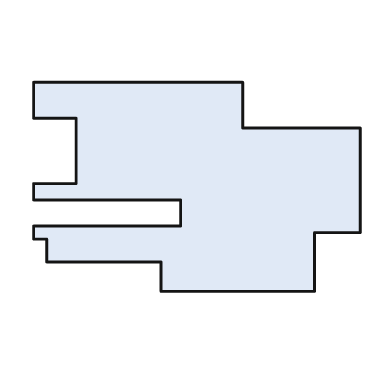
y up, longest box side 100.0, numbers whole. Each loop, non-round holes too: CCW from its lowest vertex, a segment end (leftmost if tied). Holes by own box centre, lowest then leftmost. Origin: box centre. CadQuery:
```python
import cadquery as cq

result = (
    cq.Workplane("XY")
    .moveTo(-11.0, -32.0)
    .lineTo(36.0, -32.0)
    .lineTo(36.0, -14.0)
    .lineTo(50.0, -14.0)
    .lineTo(50.0, 18.0)
    .lineTo(14.0, 18.0)
    .lineTo(14.0, 32.0)
    .lineTo(-50.0, 32.0)
    .lineTo(-50.0, 21.0)
    .lineTo(-37.0, 21.0)
    .lineTo(-37.0, 1.0)
    .lineTo(-50.0, 1.0)
    .lineTo(-50.0, -4.0)
    .lineTo(-5.0, -4.0)
    .lineTo(-5.0, -12.0)
    .lineTo(-50.0, -12.0)
    .lineTo(-50.0, -16.0)
    .lineTo(-46.0, -16.0)
    .lineTo(-46.0, -23.0)
    .lineTo(-11.0, -23.0)
    .close()
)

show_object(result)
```